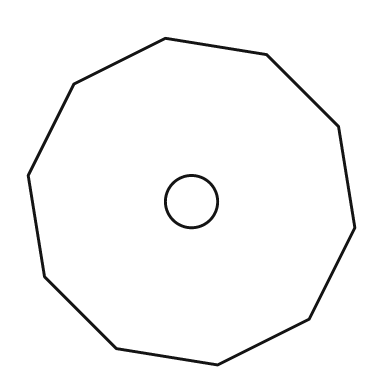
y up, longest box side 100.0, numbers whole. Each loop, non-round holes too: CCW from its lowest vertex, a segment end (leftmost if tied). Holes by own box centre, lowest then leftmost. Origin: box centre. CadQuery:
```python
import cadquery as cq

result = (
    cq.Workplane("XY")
    .moveTo(8.0, -50.0)
    .lineTo(36.0, -36.0)
    .lineTo(50.0, -8.0)
    .lineTo(45.0, 23.0)
    .lineTo(23.0, 45.0)
    .lineTo(-8.0, 50.0)
    .lineTo(-36.0, 36.0)
    .lineTo(-50.0, 8.0)
    .lineTo(-45.0, -23.0)
    .lineTo(-23.0, -45.0)
    .close()
    .moveTo(0.0, 0.0)
    .circle(8.0)
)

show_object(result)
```